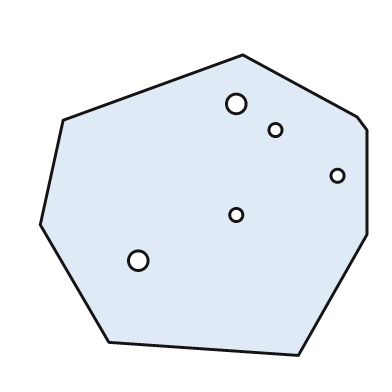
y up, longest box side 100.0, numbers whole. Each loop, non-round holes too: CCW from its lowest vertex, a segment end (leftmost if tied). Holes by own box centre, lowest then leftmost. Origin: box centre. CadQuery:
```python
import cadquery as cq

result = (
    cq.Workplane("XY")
    .moveTo(29.0, -46.0)
    .lineTo(50.0, -9.0)
    .lineTo(50.0, 23.0)
    .lineTo(47.0, 27.0)
    .lineTo(12.0, 46.0)
    .lineTo(-43.0, 26.0)
    .lineTo(-50.0, -6.0)
    .lineTo(-29.0, -42.0)
    .close()
    .moveTo(-20.0, -17.0)
    .circle(3.0)
    .moveTo(10.0, -3.0)
    .circle(2.0)
    .moveTo(41.0, 9.0)
    .circle(2.0)
    .moveTo(22.0, 23.0)
    .circle(2.0)
    .moveTo(10.0, 31.0)
    .circle(3.0)
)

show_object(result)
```